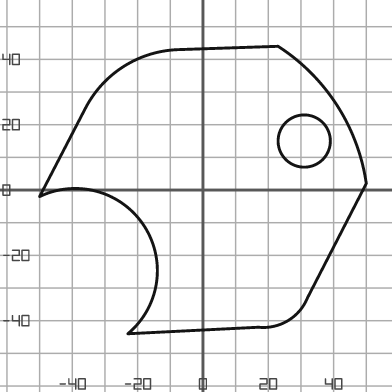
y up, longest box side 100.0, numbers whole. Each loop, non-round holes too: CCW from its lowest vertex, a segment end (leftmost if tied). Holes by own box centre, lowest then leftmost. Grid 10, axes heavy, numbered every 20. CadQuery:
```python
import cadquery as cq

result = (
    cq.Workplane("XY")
    .moveTo(-23.0, -44.0)
    .lineTo(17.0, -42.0)
    .threePointArc((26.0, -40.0), (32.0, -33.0))
    .lineTo(50.0, 2.0)
    .threePointArc((41.0, 26.0), (23.0, 44.0))
    .lineTo(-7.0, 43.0)
    .threePointArc((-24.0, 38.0), (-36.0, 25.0))
    .lineTo(-50.0, -2.0)
    .threePointArc((-18.0, -11.0), (-23.0, -44.0))
    .close()
    .moveTo(31.0, 15.0)
    .circle(8.0)
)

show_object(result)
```